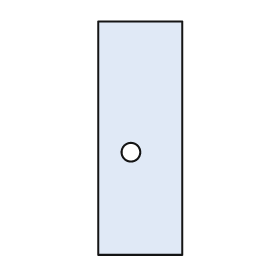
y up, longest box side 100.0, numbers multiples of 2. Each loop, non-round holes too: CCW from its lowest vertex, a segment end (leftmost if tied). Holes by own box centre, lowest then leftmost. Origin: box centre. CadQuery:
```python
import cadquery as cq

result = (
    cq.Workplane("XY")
    .moveTo(-18.0, -50.0)
    .lineTo(18.0, -50.0)
    .lineTo(18.0, 50.0)
    .lineTo(-18.0, 50.0)
    .close()
    .moveTo(-4.0, -6.0)
    .circle(4.0)
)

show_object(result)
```